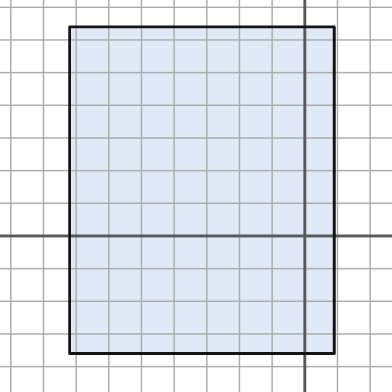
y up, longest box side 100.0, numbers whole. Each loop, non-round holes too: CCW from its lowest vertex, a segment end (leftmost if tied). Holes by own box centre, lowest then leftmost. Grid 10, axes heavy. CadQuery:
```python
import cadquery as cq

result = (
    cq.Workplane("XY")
    .moveTo(-72.0, -36.0)
    .lineTo(9.0, -36.0)
    .lineTo(9.0, 64.0)
    .lineTo(-72.0, 64.0)
    .close()
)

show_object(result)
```